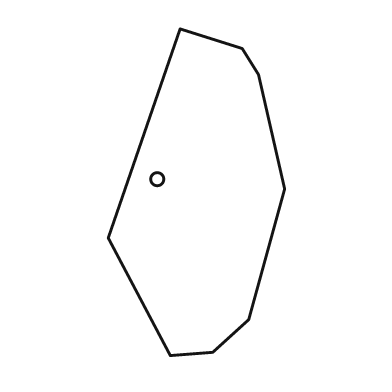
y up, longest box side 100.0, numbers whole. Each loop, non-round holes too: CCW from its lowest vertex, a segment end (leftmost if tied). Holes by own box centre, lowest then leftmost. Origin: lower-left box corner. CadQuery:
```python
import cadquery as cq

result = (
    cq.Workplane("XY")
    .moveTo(19.0, 0.0)
    .lineTo(32.0, 1.0)
    .lineTo(43.0, 11.0)
    .lineTo(54.0, 51.0)
    .lineTo(46.0, 86.0)
    .lineTo(41.0, 94.0)
    .lineTo(22.0, 100.0)
    .lineTo(0.0, 36.0)
    .close()
    .moveTo(15.0, 54.0)
    .circle(2.0)
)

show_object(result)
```